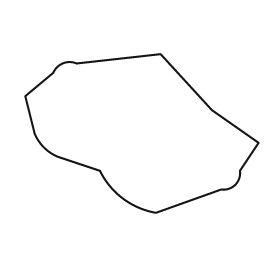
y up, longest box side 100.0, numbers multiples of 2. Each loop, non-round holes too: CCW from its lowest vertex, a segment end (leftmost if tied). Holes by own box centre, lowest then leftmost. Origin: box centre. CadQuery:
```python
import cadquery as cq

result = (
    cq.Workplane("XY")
    .moveTo(6.0, -34.0)
    .lineTo(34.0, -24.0)
    .threePointArc((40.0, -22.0), (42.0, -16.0))
    .lineTo(50.0, -4.0)
    .lineTo(30.0, 10.0)
    .lineTo(8.0, 34.0)
    .lineTo(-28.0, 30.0)
    .threePointArc((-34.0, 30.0), (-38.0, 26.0))
    .lineTo(-50.0, 16.0)
    .lineTo(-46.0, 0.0)
    .threePointArc((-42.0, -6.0), (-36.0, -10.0))
    .lineTo(-18.0, -16.0)
    .threePointArc((-8.0, -28.0), (6.0, -34.0))
    .close()
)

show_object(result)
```